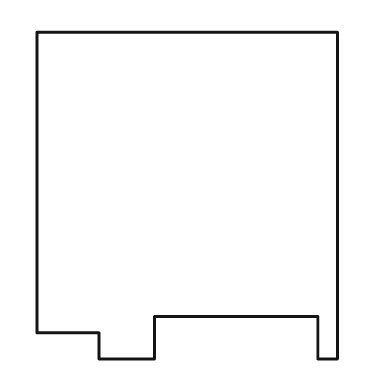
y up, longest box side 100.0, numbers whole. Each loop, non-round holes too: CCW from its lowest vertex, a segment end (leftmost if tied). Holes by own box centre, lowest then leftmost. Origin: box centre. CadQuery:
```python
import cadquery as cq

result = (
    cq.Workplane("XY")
    .moveTo(-27.0, -50.0)
    .lineTo(-10.0, -50.0)
    .lineTo(-10.0, -37.0)
    .lineTo(40.0, -37.0)
    .lineTo(40.0, -50.0)
    .lineTo(46.0, -50.0)
    .lineTo(46.0, 50.0)
    .lineTo(-46.0, 50.0)
    .lineTo(-46.0, -42.0)
    .lineTo(-27.0, -42.0)
    .close()
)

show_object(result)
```